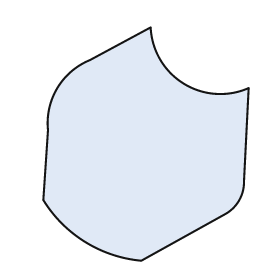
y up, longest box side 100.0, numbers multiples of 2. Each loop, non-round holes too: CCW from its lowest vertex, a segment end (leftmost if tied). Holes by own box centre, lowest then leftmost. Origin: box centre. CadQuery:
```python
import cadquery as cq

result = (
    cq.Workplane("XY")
    .moveTo(-2.0, -50.0)
    .lineTo(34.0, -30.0)
    .threePointArc((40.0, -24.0), (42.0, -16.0))
    .lineTo(44.0, 24.0)
    .threePointArc((16.0, 26.0), (2.0, 50.0))
    .lineTo(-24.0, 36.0)
    .threePointArc((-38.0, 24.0), (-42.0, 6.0))
    .lineTo(-44.0, -24.0)
    .threePointArc((-26.0, -42.0), (-2.0, -50.0))
    .close()
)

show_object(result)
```